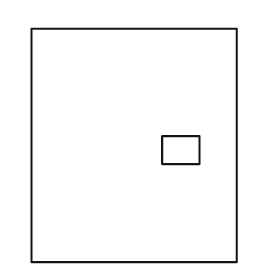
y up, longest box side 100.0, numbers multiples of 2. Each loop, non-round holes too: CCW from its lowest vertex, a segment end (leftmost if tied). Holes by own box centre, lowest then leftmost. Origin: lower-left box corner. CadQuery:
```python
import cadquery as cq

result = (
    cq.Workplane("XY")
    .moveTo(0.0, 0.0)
    .lineTo(88.0, 0.0)
    .lineTo(88.0, 100.0)
    .lineTo(0.0, 100.0)
    .close()
    .moveTo(56.0, 42.0)
    .lineTo(72.0, 42.0)
    .lineTo(72.0, 54.0)
    .lineTo(56.0, 54.0)
    .close()
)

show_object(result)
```